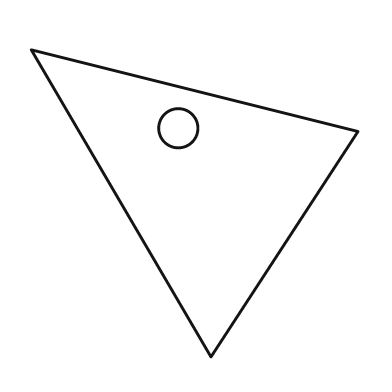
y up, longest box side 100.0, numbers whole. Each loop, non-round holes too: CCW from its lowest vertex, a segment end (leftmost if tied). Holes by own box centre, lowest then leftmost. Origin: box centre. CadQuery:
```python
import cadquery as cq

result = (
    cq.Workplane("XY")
    .moveTo(5.0, -47.0)
    .lineTo(50.0, 22.0)
    .lineTo(-50.0, 47.0)
    .close()
    .moveTo(-5.0, 23.0)
    .circle(6.0)
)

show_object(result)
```